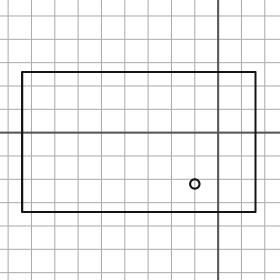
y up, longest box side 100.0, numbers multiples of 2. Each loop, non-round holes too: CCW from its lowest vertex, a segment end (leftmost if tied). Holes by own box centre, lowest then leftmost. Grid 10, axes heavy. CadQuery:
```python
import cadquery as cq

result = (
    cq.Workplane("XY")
    .moveTo(-84.0, -34.0)
    .lineTo(16.0, -34.0)
    .lineTo(16.0, 26.0)
    .lineTo(-84.0, 26.0)
    .close()
    .moveTo(-10.0, -22.0)
    .circle(2.0)
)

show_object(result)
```